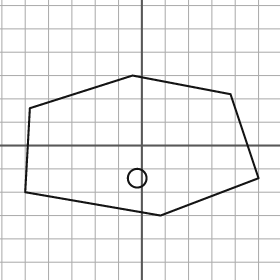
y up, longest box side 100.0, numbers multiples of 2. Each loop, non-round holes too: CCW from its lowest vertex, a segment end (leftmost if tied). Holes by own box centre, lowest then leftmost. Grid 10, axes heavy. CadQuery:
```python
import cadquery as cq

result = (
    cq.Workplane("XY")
    .moveTo(8.0, -30.0)
    .lineTo(50.0, -14.0)
    .lineTo(38.0, 22.0)
    .lineTo(-4.0, 30.0)
    .lineTo(-48.0, 16.0)
    .lineTo(-50.0, -20.0)
    .close()
    .moveTo(-2.0, -14.0)
    .circle(4.0)
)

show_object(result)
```